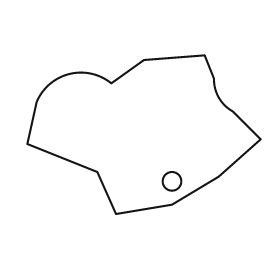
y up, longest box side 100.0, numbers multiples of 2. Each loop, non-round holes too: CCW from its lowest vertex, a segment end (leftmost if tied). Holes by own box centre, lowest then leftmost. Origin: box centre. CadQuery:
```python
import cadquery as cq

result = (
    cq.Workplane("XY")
    .moveTo(-12.0, -34.0)
    .lineTo(12.0, -30.0)
    .lineTo(32.0, -18.0)
    .lineTo(50.0, -2.0)
    .lineTo(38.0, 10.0)
    .threePointArc((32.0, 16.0), (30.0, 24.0))
    .lineTo(26.0, 34.0)
    .lineTo(0.0, 32.0)
    .lineTo(-14.0, 22.0)
    .threePointArc((-32.0, 26.0), (-46.0, 14.0))
    .lineTo(-50.0, -4.0)
    .lineTo(-20.0, -16.0)
    .close()
    .moveTo(12.0, -20.0)
    .circle(4.0)
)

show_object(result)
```